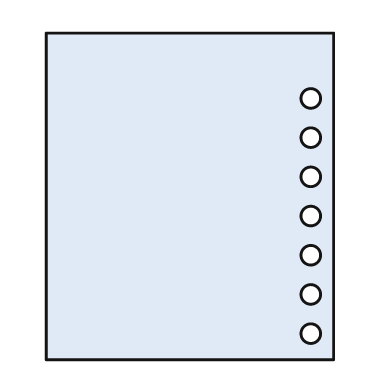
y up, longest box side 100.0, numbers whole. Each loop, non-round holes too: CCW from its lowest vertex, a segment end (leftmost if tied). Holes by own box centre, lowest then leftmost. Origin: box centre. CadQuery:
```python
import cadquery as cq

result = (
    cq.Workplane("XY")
    .moveTo(-44.0, -50.0)
    .lineTo(44.0, -50.0)
    .lineTo(44.0, 50.0)
    .lineTo(-44.0, 50.0)
    .close()
    .moveTo(37.0, -42.0)
    .circle(3.0)
    .moveTo(37.0, -30.0)
    .circle(3.0)
    .moveTo(37.0, -18.0)
    .circle(3.0)
    .moveTo(37.0, -6.0)
    .circle(3.0)
    .moveTo(37.0, 6.0)
    .circle(3.0)
    .moveTo(37.0, 18.0)
    .circle(3.0)
    .moveTo(37.0, 30.0)
    .circle(3.0)
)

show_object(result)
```